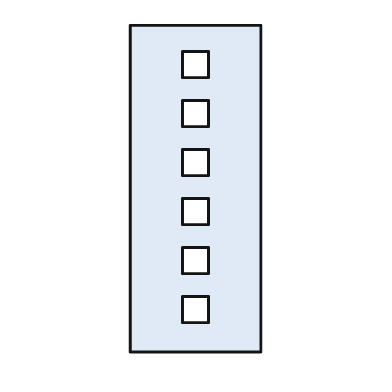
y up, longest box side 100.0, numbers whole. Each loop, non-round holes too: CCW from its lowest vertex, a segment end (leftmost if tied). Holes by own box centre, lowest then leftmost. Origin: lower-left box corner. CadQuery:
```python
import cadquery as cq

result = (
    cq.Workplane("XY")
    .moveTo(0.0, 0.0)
    .lineTo(40.0, 0.0)
    .lineTo(40.0, 100.0)
    .lineTo(0.0, 100.0)
    .close()
    .moveTo(16.0, 9.0)
    .lineTo(24.0, 9.0)
    .lineTo(24.0, 17.0)
    .lineTo(16.0, 17.0)
    .close()
    .moveTo(16.0, 24.0)
    .lineTo(24.0, 24.0)
    .lineTo(24.0, 32.0)
    .lineTo(16.0, 32.0)
    .close()
    .moveTo(16.0, 39.0)
    .lineTo(24.0, 39.0)
    .lineTo(24.0, 47.0)
    .lineTo(16.0, 47.0)
    .close()
    .moveTo(16.0, 54.0)
    .lineTo(24.0, 54.0)
    .lineTo(24.0, 62.0)
    .lineTo(16.0, 62.0)
    .close()
    .moveTo(16.0, 69.0)
    .lineTo(24.0, 69.0)
    .lineTo(24.0, 77.0)
    .lineTo(16.0, 77.0)
    .close()
    .moveTo(16.0, 84.0)
    .lineTo(24.0, 84.0)
    .lineTo(24.0, 92.0)
    .lineTo(16.0, 92.0)
    .close()
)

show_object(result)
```